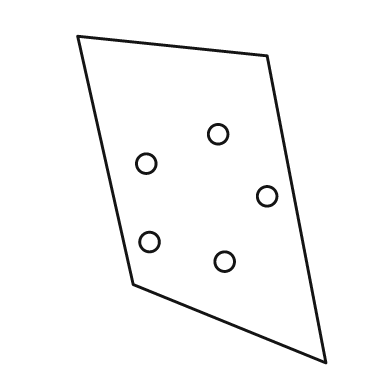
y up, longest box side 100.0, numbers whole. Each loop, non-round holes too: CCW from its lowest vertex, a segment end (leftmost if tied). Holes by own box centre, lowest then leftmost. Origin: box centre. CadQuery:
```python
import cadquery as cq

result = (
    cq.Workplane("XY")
    .moveTo(38.0, -50.0)
    .lineTo(20.0, 44.0)
    .lineTo(-38.0, 50.0)
    .lineTo(-21.0, -26.0)
    .close()
    .moveTo(7.0, -19.0)
    .circle(3.0)
    .moveTo(-16.0, -13.0)
    .circle(3.0)
    .moveTo(20.0, 1.0)
    .circle(3.0)
    .moveTo(-17.0, 11.0)
    .circle(3.0)
    .moveTo(5.0, 20.0)
    .circle(3.0)
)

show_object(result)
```